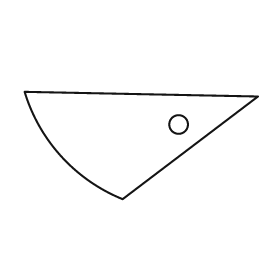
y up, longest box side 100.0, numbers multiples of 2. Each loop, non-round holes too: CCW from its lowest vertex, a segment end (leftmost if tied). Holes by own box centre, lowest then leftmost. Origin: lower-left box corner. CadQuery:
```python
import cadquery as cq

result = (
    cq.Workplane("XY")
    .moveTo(42.0, 0.0)
    .lineTo(100.0, 44.0)
    .lineTo(0.0, 46.0)
    .threePointArc((16.0, 18.0), (42.0, 0.0))
    .close()
    .moveTo(66.0, 32.0)
    .circle(4.0)
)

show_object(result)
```